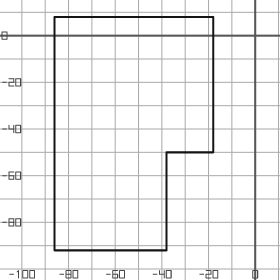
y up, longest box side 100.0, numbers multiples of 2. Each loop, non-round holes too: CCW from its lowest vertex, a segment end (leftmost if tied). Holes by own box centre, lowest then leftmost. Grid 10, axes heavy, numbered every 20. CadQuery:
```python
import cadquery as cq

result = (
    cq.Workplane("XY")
    .moveTo(-86.0, -92.0)
    .lineTo(-38.0, -92.0)
    .lineTo(-38.0, -50.0)
    .lineTo(-18.0, -50.0)
    .lineTo(-18.0, 8.0)
    .lineTo(-86.0, 8.0)
    .close()
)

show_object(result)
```